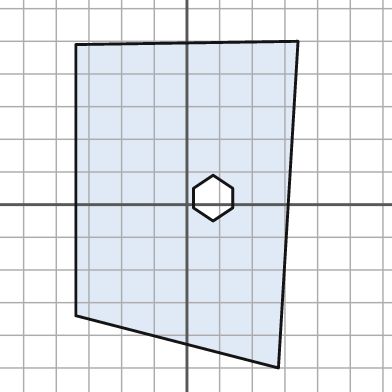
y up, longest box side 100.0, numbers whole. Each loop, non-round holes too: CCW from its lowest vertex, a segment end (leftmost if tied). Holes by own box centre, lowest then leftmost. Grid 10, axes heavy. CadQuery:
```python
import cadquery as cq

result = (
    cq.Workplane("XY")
    .moveTo(28.0, -50.0)
    .lineTo(34.0, 50.0)
    .lineTo(-34.0, 49.0)
    .lineTo(-34.0, -34.0)
    .close()
    .moveTo(8.0, -5.0)
    .lineTo(14.0, -1.0)
    .lineTo(14.0, 5.0)
    .lineTo(8.0, 9.0)
    .lineTo(2.0, 5.0)
    .lineTo(2.0, -1.0)
    .close()
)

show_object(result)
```